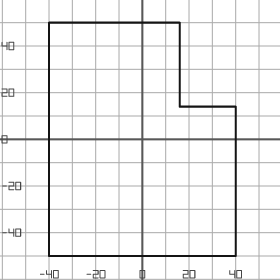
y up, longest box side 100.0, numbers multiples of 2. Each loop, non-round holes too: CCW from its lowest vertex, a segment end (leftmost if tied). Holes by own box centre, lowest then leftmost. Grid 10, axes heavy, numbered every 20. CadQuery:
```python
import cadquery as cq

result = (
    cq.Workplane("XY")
    .moveTo(-40.0, -50.0)
    .lineTo(40.0, -50.0)
    .lineTo(40.0, 14.0)
    .lineTo(16.0, 14.0)
    .lineTo(16.0, 50.0)
    .lineTo(-40.0, 50.0)
    .close()
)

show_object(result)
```